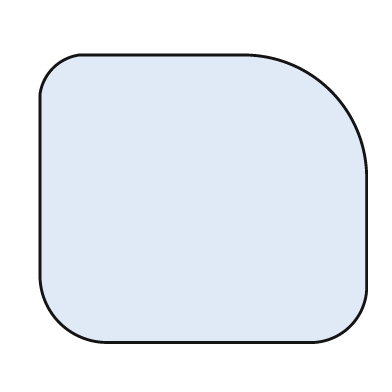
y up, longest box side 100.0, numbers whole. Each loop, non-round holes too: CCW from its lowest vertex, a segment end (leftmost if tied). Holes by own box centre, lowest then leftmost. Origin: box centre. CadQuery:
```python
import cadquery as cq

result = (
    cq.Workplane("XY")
    .moveTo(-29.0, -44.0)
    .lineTo(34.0, -44.0)
    .threePointArc((45.0, -39.0), (50.0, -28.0))
    .lineTo(50.0, 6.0)
    .threePointArc((39.0, 33.0), (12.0, 44.0))
    .lineTo(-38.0, 44.0)
    .threePointArc((-46.0, 40.0), (-50.0, 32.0))
    .lineTo(-50.0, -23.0)
    .threePointArc((-44.0, -38.0), (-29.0, -44.0))
    .close()
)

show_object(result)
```